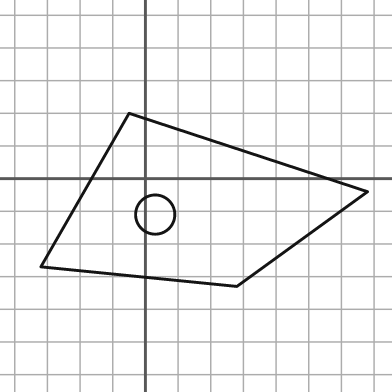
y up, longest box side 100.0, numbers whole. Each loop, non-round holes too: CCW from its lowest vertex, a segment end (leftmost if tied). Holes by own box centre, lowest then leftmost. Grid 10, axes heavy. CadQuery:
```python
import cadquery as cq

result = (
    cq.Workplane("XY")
    .moveTo(28.0, -33.0)
    .lineTo(68.0, -4.0)
    .lineTo(-5.0, 20.0)
    .lineTo(-32.0, -27.0)
    .close()
    .moveTo(3.0, -11.0)
    .circle(6.0)
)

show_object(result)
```